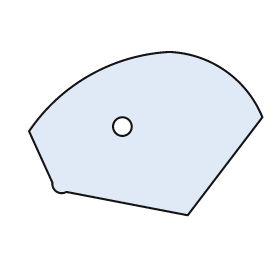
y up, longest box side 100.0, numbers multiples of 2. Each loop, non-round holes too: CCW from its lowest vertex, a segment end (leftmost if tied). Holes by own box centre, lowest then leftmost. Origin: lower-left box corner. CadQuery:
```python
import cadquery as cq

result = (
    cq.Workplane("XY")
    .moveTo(68.0, 0.0)
    .lineTo(100.0, 42.0)
    .threePointArc((84.0, 62.0), (60.0, 70.0))
    .threePointArc((26.0, 60.0), (0.0, 36.0))
    .lineTo(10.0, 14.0)
    .threePointArc((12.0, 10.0), (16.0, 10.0))
    .close()
    .moveTo(40.0, 38.0)
    .circle(4.0)
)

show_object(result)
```